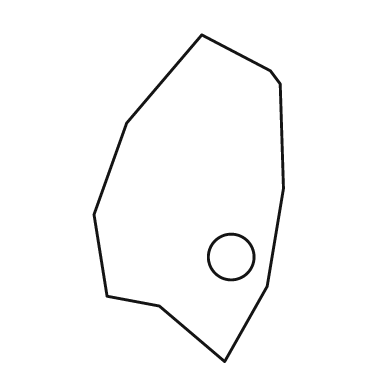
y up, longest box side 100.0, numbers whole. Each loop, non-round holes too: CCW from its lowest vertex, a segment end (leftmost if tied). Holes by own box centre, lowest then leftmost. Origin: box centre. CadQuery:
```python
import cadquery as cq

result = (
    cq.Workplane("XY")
    .moveTo(11.0, -50.0)
    .lineTo(24.0, -27.0)
    .lineTo(29.0, 3.0)
    .lineTo(28.0, 35.0)
    .lineTo(25.0, 39.0)
    .lineTo(4.0, 50.0)
    .lineTo(-19.0, 23.0)
    .lineTo(-29.0, -5.0)
    .lineTo(-25.0, -30.0)
    .lineTo(-9.0, -33.0)
    .close()
    .moveTo(13.0, -18.0)
    .circle(7.0)
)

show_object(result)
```